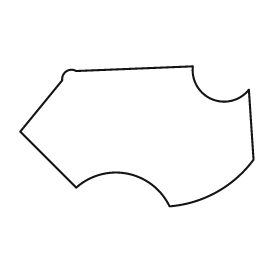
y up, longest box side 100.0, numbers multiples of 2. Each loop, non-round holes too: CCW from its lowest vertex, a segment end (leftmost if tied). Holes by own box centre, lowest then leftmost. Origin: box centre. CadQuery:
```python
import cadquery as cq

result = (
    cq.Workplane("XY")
    .moveTo(14.0, -30.0)
    .threePointArc((34.0, -24.0), (50.0, -10.0))
    .lineTo(48.0, 20.0)
    .threePointArc((32.0, 16.0), (24.0, 30.0))
    .lineTo(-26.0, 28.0)
    .threePointArc((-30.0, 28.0), (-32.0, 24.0))
    .lineTo(-50.0, 2.0)
    .lineTo(-26.0, -22.0)
    .threePointArc((-4.0, -16.0), (14.0, -30.0))
    .close()
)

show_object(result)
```